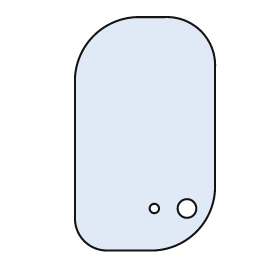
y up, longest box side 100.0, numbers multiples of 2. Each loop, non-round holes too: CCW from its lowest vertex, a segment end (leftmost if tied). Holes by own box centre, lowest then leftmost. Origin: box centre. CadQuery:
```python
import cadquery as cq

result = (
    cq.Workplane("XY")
    .moveTo(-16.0, -50.0)
    .lineTo(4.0, -50.0)
    .threePointArc((22.0, -42.0), (30.0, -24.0))
    .lineTo(30.0, 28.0)
    .threePointArc((24.0, 44.0), (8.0, 50.0))
    .lineTo(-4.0, 50.0)
    .threePointArc((-22.0, 42.0), (-30.0, 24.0))
    .lineTo(-30.0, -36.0)
    .threePointArc((-26.0, -46.0), (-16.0, -50.0))
    .close()
    .moveTo(4.0, -32.0)
    .circle(2.0)
    .moveTo(18.0, -32.0)
    .circle(4.0)
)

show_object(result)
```